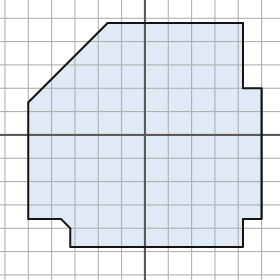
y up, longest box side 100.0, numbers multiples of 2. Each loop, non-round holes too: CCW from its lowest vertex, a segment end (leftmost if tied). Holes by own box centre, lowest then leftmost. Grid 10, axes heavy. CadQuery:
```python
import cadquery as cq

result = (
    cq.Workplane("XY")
    .moveTo(-32.0, -48.0)
    .lineTo(42.0, -48.0)
    .lineTo(42.0, -36.0)
    .lineTo(50.0, -36.0)
    .lineTo(50.0, 20.0)
    .lineTo(42.0, 20.0)
    .lineTo(42.0, 48.0)
    .lineTo(-16.0, 48.0)
    .lineTo(-50.0, 14.0)
    .lineTo(-50.0, -36.0)
    .lineTo(-36.0, -36.0)
    .lineTo(-32.0, -40.0)
    .close()
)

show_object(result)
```